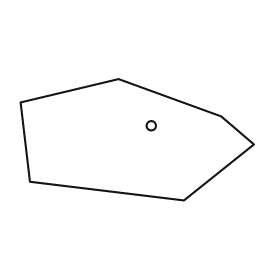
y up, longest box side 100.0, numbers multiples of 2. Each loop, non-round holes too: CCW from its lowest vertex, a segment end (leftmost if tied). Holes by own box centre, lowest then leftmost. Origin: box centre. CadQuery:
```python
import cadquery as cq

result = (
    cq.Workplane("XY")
    .moveTo(20.0, -26.0)
    .lineTo(50.0, -2.0)
    .lineTo(36.0, 10.0)
    .lineTo(-8.0, 26.0)
    .lineTo(-50.0, 16.0)
    .lineTo(-46.0, -18.0)
    .close()
    .moveTo(6.0, 6.0)
    .circle(2.0)
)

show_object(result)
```